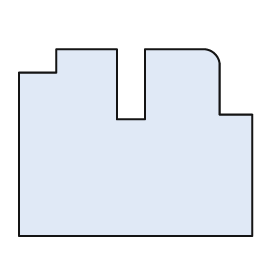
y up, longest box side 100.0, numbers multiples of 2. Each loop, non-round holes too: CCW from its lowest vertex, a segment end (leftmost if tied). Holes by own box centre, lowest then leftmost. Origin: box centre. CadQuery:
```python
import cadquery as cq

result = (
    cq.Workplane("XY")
    .moveTo(-50.0, -40.0)
    .lineTo(50.0, -40.0)
    .lineTo(50.0, 12.0)
    .lineTo(36.0, 12.0)
    .lineTo(36.0, 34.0)
    .threePointArc((34.0, 38.0), (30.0, 40.0))
    .lineTo(4.0, 40.0)
    .lineTo(4.0, 10.0)
    .lineTo(-8.0, 10.0)
    .lineTo(-8.0, 40.0)
    .lineTo(-34.0, 40.0)
    .lineTo(-34.0, 30.0)
    .lineTo(-50.0, 30.0)
    .close()
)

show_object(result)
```